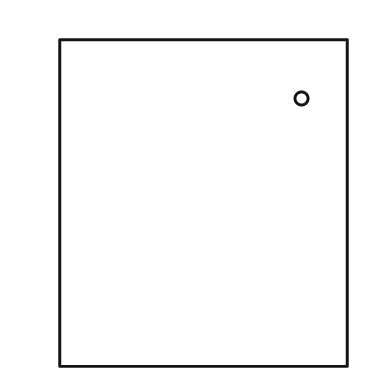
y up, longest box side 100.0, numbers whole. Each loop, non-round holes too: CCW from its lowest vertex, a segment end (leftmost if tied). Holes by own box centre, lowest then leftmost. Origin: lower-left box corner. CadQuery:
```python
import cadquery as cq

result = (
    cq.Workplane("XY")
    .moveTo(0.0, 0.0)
    .lineTo(88.0, 0.0)
    .lineTo(88.0, 100.0)
    .lineTo(0.0, 100.0)
    .close()
    .moveTo(74.0, 82.0)
    .circle(2.0)
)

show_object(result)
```